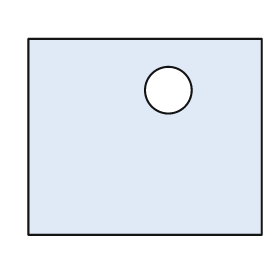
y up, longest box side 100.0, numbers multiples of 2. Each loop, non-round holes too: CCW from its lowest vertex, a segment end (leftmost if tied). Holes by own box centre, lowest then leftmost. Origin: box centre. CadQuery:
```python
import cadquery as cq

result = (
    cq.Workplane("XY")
    .moveTo(-50.0, -42.0)
    .lineTo(50.0, -42.0)
    .lineTo(50.0, 42.0)
    .lineTo(-50.0, 42.0)
    .close()
    .moveTo(10.0, 20.0)
    .circle(10.0)
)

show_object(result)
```